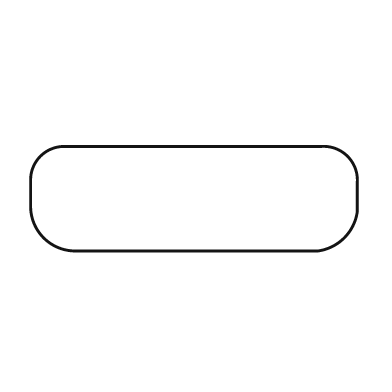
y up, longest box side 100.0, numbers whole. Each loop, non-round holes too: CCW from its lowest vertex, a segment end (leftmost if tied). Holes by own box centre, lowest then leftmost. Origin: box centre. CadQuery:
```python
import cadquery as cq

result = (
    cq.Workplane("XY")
    .moveTo(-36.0, -16.0)
    .lineTo(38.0, -16.0)
    .threePointArc((46.0, -12.0), (50.0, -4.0))
    .lineTo(50.0, 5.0)
    .threePointArc((47.0, 13.0), (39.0, 16.0))
    .lineTo(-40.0, 16.0)
    .threePointArc((-47.0, 13.0), (-50.0, 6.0))
    .lineTo(-50.0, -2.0)
    .threePointArc((-46.0, -12.0), (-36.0, -16.0))
    .close()
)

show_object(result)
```